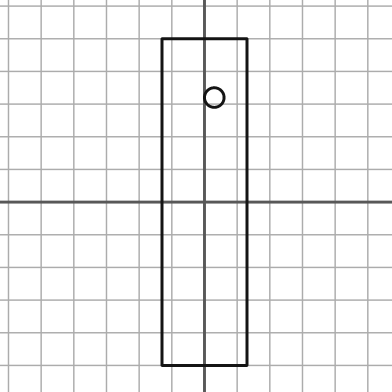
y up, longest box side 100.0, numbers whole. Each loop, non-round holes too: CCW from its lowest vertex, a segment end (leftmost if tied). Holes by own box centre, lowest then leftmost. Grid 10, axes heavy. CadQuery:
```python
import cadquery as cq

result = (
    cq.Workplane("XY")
    .moveTo(-13.0, -50.0)
    .lineTo(13.0, -50.0)
    .lineTo(13.0, 50.0)
    .lineTo(-13.0, 50.0)
    .close()
    .moveTo(3.0, 32.0)
    .circle(3.0)
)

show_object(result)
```